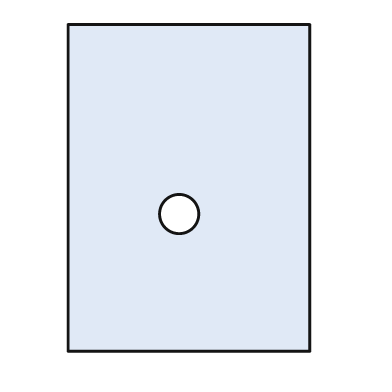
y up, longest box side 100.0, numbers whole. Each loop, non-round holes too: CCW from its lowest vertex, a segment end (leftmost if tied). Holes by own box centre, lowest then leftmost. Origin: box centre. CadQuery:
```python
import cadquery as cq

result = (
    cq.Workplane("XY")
    .moveTo(-37.0, -50.0)
    .lineTo(37.0, -50.0)
    .lineTo(37.0, 50.0)
    .lineTo(-37.0, 50.0)
    .close()
    .moveTo(-3.0, -8.0)
    .circle(6.0)
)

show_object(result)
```